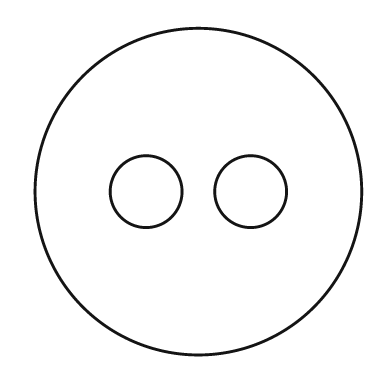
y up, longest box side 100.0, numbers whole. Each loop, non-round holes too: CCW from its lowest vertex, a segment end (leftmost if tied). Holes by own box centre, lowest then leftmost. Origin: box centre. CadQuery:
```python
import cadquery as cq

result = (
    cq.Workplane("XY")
    .moveTo(0.0, 0.0)
    .circle(50.0)
    .moveTo(-16.0, 0.0)
    .circle(11.0)
    .moveTo(16.0, 0.0)
    .circle(11.0)
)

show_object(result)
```